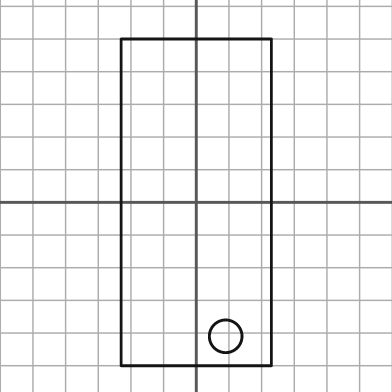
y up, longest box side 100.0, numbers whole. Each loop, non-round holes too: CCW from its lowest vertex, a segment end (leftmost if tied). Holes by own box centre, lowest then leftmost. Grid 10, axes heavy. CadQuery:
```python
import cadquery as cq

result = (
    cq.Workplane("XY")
    .moveTo(-23.0, -50.0)
    .lineTo(23.0, -50.0)
    .lineTo(23.0, 50.0)
    .lineTo(-23.0, 50.0)
    .close()
    .moveTo(9.0, -41.0)
    .circle(5.0)
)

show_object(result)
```